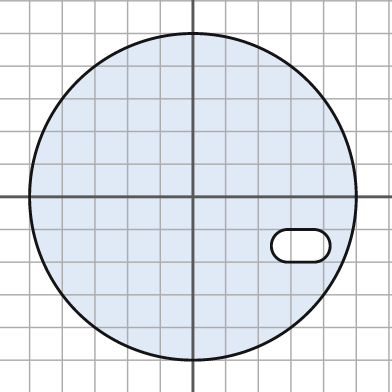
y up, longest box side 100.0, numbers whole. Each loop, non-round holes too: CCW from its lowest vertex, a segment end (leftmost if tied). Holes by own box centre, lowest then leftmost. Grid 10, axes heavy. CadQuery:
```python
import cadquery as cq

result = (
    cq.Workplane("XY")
    .moveTo(0.0, 0.0)
    .circle(50.0)
    .moveTo(29.0, -20.0)
    .lineTo(37.0, -20.0)
    .threePointArc((42.0, -15.0), (37.0, -10.0))
    .lineTo(29.0, -10.0)
    .threePointArc((24.0, -15.0), (29.0, -20.0))
    .close()
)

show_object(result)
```